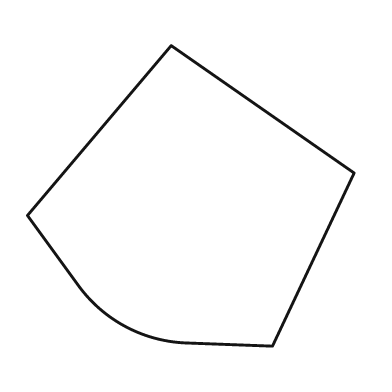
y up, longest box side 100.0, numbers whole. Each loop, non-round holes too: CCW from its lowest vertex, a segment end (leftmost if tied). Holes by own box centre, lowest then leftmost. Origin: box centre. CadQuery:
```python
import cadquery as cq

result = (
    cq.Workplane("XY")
    .moveTo(25.0, -46.0)
    .lineTo(50.0, 7.0)
    .lineTo(-6.0, 46.0)
    .lineTo(-50.0, -6.0)
    .lineTo(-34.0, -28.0)
    .threePointArc((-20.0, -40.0), (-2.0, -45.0))
    .close()
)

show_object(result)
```